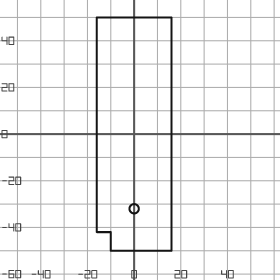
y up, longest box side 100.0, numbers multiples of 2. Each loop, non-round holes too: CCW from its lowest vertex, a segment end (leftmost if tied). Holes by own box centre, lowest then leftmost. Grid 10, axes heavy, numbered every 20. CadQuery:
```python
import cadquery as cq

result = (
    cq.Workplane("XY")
    .moveTo(-10.0, -50.0)
    .lineTo(16.0, -50.0)
    .lineTo(16.0, 50.0)
    .lineTo(-16.0, 50.0)
    .lineTo(-16.0, -42.0)
    .lineTo(-10.0, -42.0)
    .close()
    .moveTo(0.0, -32.0)
    .circle(2.0)
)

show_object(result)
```